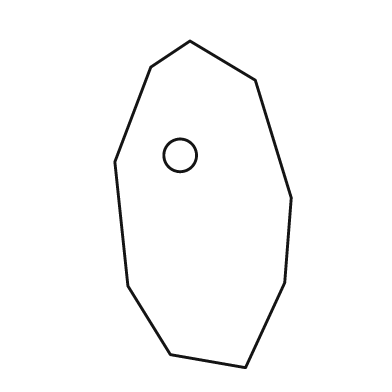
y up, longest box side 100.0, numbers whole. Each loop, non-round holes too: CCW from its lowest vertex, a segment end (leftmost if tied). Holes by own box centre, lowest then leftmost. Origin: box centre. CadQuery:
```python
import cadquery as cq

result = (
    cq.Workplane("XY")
    .moveTo(13.0, -50.0)
    .lineTo(25.0, -24.0)
    .lineTo(27.0, 2.0)
    .lineTo(16.0, 38.0)
    .lineTo(-4.0, 50.0)
    .lineTo(-16.0, 42.0)
    .lineTo(-27.0, 13.0)
    .lineTo(-23.0, -25.0)
    .lineTo(-10.0, -46.0)
    .close()
    .moveTo(-7.0, 15.0)
    .circle(5.0)
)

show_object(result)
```